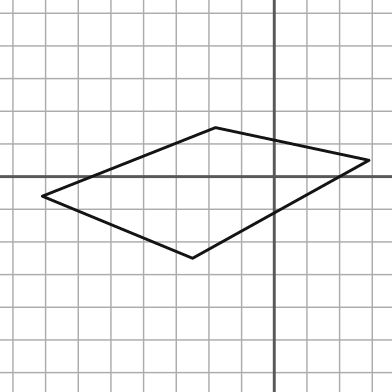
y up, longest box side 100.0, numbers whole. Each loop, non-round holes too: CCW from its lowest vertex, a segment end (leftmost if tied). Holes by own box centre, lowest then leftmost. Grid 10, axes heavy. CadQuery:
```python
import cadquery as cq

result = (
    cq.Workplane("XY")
    .moveTo(-25.0, -25.0)
    .lineTo(29.0, 5.0)
    .lineTo(-18.0, 15.0)
    .lineTo(-71.0, -6.0)
    .close()
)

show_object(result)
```